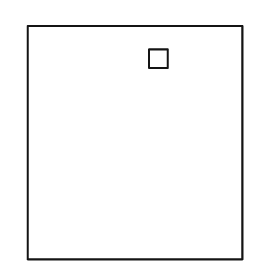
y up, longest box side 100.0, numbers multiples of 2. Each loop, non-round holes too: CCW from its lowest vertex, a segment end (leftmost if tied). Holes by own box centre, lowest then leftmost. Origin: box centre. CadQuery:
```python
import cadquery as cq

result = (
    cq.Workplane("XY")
    .moveTo(-46.0, -50.0)
    .lineTo(46.0, -50.0)
    .lineTo(46.0, 50.0)
    .lineTo(-46.0, 50.0)
    .close()
    .moveTo(6.0, 32.0)
    .lineTo(14.0, 32.0)
    .lineTo(14.0, 40.0)
    .lineTo(6.0, 40.0)
    .close()
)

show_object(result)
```